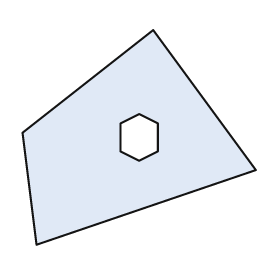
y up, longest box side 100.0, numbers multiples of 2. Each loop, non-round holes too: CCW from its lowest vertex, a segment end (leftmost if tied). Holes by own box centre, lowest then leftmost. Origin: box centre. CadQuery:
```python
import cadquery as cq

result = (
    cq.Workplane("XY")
    .moveTo(-44.0, -46.0)
    .lineTo(50.0, -14.0)
    .lineTo(6.0, 46.0)
    .lineTo(-50.0, 2.0)
    .close()
    .moveTo(0.0, -10.0)
    .lineTo(8.0, -6.0)
    .lineTo(8.0, 6.0)
    .lineTo(0.0, 10.0)
    .lineTo(-8.0, 6.0)
    .lineTo(-8.0, -6.0)
    .close()
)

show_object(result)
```